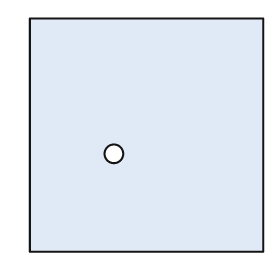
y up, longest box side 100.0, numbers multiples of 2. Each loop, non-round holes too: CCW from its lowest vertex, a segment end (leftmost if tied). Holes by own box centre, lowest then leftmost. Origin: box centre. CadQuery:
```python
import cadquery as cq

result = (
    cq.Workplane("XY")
    .moveTo(-50.0, -50.0)
    .lineTo(50.0, -50.0)
    .lineTo(50.0, 50.0)
    .lineTo(-50.0, 50.0)
    .close()
    .moveTo(-14.0, -8.0)
    .circle(4.0)
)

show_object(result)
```